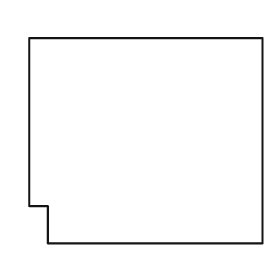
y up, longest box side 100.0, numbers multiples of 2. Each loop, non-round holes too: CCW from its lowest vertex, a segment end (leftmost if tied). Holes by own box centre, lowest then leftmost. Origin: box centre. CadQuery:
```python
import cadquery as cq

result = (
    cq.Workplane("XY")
    .moveTo(-42.0, -44.0)
    .lineTo(50.0, -44.0)
    .lineTo(50.0, 44.0)
    .lineTo(-50.0, 44.0)
    .lineTo(-50.0, -28.0)
    .lineTo(-42.0, -28.0)
    .close()
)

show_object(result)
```